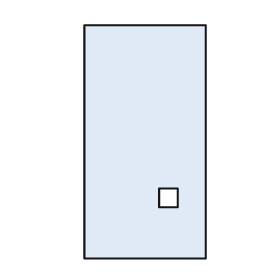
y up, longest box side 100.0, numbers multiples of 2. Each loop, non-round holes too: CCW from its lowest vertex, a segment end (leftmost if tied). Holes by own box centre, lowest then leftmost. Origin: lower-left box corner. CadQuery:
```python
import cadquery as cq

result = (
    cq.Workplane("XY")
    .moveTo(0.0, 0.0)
    .lineTo(52.0, 0.0)
    .lineTo(52.0, 100.0)
    .lineTo(0.0, 100.0)
    .close()
    .moveTo(32.0, 22.0)
    .lineTo(40.0, 22.0)
    .lineTo(40.0, 30.0)
    .lineTo(32.0, 30.0)
    .close()
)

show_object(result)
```